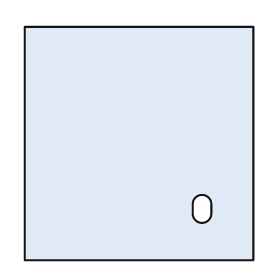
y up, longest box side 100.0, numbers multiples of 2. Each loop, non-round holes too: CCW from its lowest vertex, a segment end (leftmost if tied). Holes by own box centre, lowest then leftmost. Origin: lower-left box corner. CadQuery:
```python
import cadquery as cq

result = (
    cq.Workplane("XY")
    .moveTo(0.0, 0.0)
    .lineTo(98.0, 0.0)
    .lineTo(98.0, 100.0)
    .lineTo(0.0, 100.0)
    .close()
    .moveTo(72.0, 20.0)
    .threePointArc((76.0, 16.0), (80.0, 20.0))
    .lineTo(80.0, 24.0)
    .threePointArc((76.0, 28.0), (72.0, 24.0))
    .close()
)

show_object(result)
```